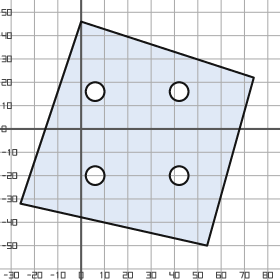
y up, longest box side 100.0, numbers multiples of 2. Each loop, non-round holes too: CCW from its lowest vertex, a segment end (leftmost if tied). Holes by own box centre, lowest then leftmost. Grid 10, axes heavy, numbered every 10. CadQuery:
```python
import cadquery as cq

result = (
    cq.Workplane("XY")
    .moveTo(54.0, -50.0)
    .lineTo(74.0, 22.0)
    .lineTo(0.0, 46.0)
    .lineTo(-26.0, -32.0)
    .close()
    .moveTo(6.0, -20.0)
    .circle(4.0)
    .moveTo(42.0, -20.0)
    .circle(4.0)
    .moveTo(6.0, 16.0)
    .circle(4.0)
    .moveTo(42.0, 16.0)
    .circle(4.0)
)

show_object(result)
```